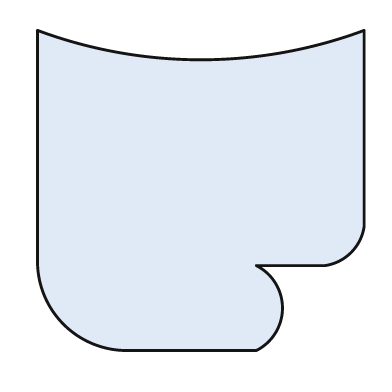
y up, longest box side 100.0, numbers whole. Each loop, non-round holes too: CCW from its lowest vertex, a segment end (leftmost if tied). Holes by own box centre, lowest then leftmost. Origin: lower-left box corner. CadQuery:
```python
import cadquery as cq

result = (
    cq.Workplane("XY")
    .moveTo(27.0, 0.0)
    .lineTo(67.0, 0.0)
    .threePointArc((75.0, 13.0), (67.0, 26.0))
    .lineTo(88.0, 26.0)
    .threePointArc((96.0, 30.0), (100.0, 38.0))
    .lineTo(100.0, 98.0)
    .threePointArc((50.0, 89.0), (0.0, 98.0))
    .lineTo(0.0, 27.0)
    .threePointArc((8.0, 8.0), (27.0, 0.0))
    .close()
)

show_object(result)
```